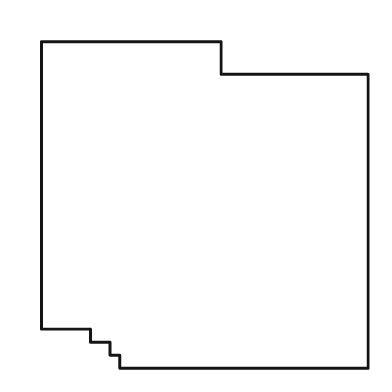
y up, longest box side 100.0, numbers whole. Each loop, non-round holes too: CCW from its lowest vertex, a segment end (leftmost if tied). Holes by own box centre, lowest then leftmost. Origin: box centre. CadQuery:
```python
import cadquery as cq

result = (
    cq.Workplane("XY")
    .moveTo(-26.0, -50.0)
    .lineTo(50.0, -50.0)
    .lineTo(50.0, 40.0)
    .lineTo(5.0, 40.0)
    .lineTo(5.0, 50.0)
    .lineTo(-50.0, 50.0)
    .lineTo(-50.0, -38.0)
    .lineTo(-35.0, -38.0)
    .lineTo(-35.0, -42.0)
    .lineTo(-29.0, -42.0)
    .lineTo(-29.0, -46.0)
    .lineTo(-26.0, -46.0)
    .close()
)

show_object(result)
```